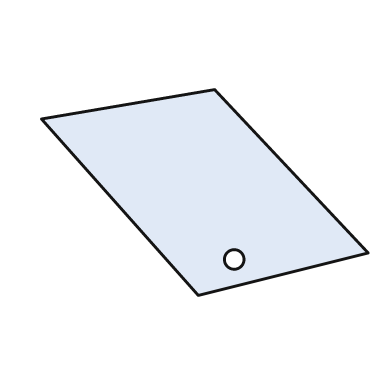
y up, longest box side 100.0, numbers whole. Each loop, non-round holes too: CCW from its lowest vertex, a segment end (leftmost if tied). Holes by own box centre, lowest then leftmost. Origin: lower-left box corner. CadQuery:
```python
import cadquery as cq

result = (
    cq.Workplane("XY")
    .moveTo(48.0, 0.0)
    .lineTo(100.0, 13.0)
    .lineTo(53.0, 63.0)
    .lineTo(0.0, 54.0)
    .close()
    .moveTo(59.0, 11.0)
    .circle(3.0)
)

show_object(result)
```